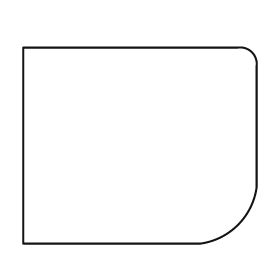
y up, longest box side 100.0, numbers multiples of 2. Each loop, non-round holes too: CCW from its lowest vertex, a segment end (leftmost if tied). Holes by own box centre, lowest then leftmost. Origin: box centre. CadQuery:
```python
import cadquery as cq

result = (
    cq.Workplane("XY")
    .moveTo(-50.0, -42.0)
    .lineTo(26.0, -42.0)
    .threePointArc((42.0, -34.0), (50.0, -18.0))
    .lineTo(50.0, 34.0)
    .threePointArc((48.0, 40.0), (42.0, 42.0))
    .lineTo(-50.0, 42.0)
    .close()
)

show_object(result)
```